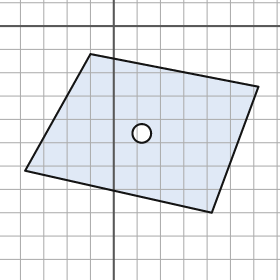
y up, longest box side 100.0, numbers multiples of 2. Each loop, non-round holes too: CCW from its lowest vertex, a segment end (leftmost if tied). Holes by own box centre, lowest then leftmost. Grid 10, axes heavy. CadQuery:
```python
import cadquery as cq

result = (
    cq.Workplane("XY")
    .moveTo(42.0, -80.0)
    .lineTo(62.0, -26.0)
    .lineTo(-10.0, -12.0)
    .lineTo(-38.0, -62.0)
    .close()
    .moveTo(12.0, -46.0)
    .circle(4.0)
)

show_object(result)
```